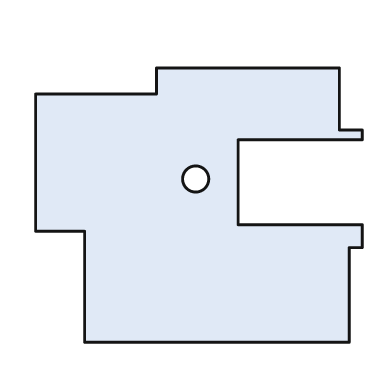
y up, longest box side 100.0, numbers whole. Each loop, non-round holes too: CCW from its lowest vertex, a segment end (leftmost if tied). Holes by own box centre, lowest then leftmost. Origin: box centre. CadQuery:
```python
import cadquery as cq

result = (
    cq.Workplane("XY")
    .moveTo(-35.0, -42.0)
    .lineTo(46.0, -42.0)
    .lineTo(46.0, -13.0)
    .lineTo(50.0, -13.0)
    .lineTo(50.0, -6.0)
    .lineTo(12.0, -6.0)
    .lineTo(12.0, 20.0)
    .lineTo(50.0, 20.0)
    .lineTo(50.0, 23.0)
    .lineTo(43.0, 23.0)
    .lineTo(43.0, 42.0)
    .lineTo(-13.0, 42.0)
    .lineTo(-13.0, 34.0)
    .lineTo(-50.0, 34.0)
    .lineTo(-50.0, -8.0)
    .lineTo(-35.0, -8.0)
    .close()
    .moveTo(-1.0, 8.0)
    .circle(4.0)
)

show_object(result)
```